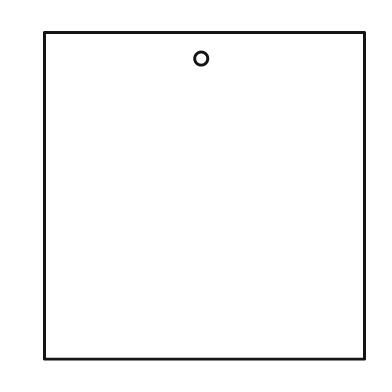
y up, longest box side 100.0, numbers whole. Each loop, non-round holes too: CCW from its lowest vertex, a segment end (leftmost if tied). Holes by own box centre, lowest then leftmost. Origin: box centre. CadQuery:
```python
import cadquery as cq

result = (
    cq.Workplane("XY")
    .moveTo(-49.0, -50.0)
    .lineTo(49.0, -50.0)
    .lineTo(49.0, 50.0)
    .lineTo(-49.0, 50.0)
    .close()
    .moveTo(-1.0, 42.0)
    .circle(2.0)
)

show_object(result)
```